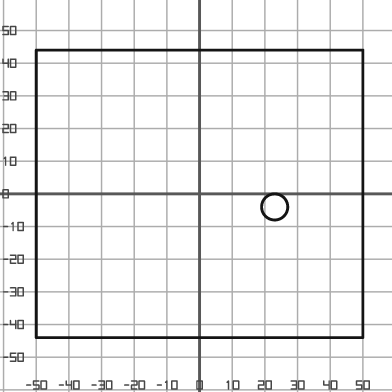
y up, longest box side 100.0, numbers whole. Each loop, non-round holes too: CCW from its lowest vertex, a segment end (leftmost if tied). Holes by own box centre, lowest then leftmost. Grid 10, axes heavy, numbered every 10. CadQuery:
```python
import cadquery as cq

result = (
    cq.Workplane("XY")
    .moveTo(-50.0, -44.0)
    .lineTo(50.0, -44.0)
    .lineTo(50.0, 44.0)
    .lineTo(-50.0, 44.0)
    .close()
    .moveTo(23.0, -4.0)
    .circle(4.0)
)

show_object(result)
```